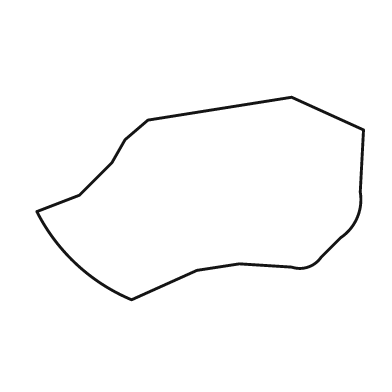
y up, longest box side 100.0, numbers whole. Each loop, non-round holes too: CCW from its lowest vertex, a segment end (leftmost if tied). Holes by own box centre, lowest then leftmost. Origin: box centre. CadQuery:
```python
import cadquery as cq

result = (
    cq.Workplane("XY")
    .moveTo(-21.0, -31.0)
    .lineTo(-1.0, -22.0)
    .lineTo(12.0, -20.0)
    .lineTo(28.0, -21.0)
    .threePointArc((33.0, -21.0), (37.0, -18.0))
    .lineTo(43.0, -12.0)
    .threePointArc((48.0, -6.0), (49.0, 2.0))
    .lineTo(50.0, 21.0)
    .lineTo(28.0, 31.0)
    .lineTo(-16.0, 24.0)
    .lineTo(-23.0, 18.0)
    .lineTo(-27.0, 11.0)
    .lineTo(-37.0, 1.0)
    .lineTo(-50.0, -4.0)
    .threePointArc((-38.0, -20.0), (-21.0, -31.0))
    .close()
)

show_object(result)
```